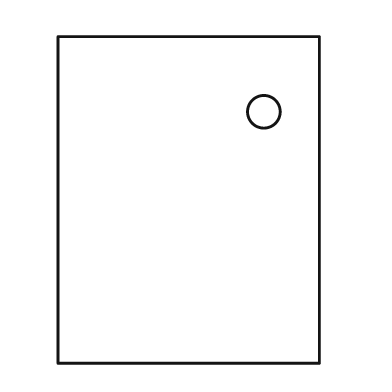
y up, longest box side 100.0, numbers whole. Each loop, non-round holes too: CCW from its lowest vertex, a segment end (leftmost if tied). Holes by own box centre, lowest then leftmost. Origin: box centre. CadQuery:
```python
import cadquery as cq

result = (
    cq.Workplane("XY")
    .moveTo(-40.0, -50.0)
    .lineTo(40.0, -50.0)
    .lineTo(40.0, 50.0)
    .lineTo(-40.0, 50.0)
    .close()
    .moveTo(23.0, 27.0)
    .circle(5.0)
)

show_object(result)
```